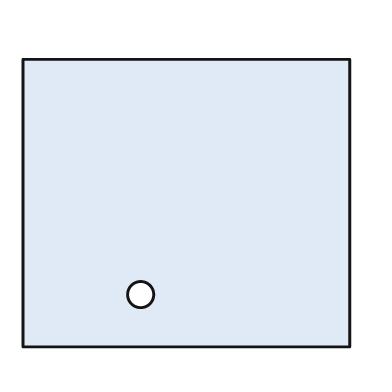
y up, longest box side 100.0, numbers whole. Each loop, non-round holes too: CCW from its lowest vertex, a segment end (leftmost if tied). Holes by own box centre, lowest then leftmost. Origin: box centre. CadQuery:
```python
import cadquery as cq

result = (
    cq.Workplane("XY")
    .moveTo(-50.0, -44.0)
    .lineTo(50.0, -44.0)
    .lineTo(50.0, 44.0)
    .lineTo(-50.0, 44.0)
    .close()
    .moveTo(-14.0, -28.0)
    .circle(4.0)
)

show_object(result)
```